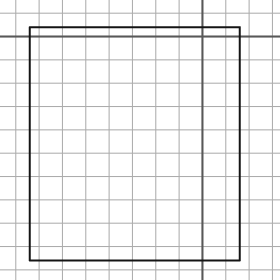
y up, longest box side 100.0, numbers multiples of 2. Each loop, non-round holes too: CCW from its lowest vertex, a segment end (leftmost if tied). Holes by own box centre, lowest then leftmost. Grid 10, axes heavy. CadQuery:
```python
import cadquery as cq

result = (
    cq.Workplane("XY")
    .moveTo(-74.0, -96.0)
    .lineTo(16.0, -96.0)
    .lineTo(16.0, 4.0)
    .lineTo(-74.0, 4.0)
    .close()
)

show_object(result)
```